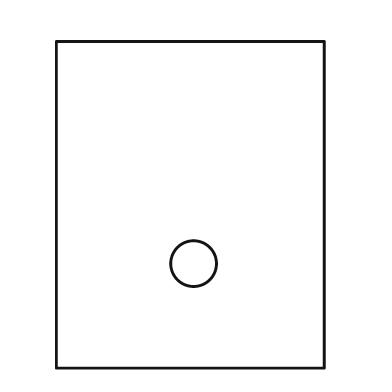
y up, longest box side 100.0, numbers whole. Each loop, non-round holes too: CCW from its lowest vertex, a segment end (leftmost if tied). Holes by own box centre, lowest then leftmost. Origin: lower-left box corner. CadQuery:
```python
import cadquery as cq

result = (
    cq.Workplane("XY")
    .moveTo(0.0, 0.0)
    .lineTo(82.0, 0.0)
    .lineTo(82.0, 100.0)
    .lineTo(0.0, 100.0)
    .close()
    .moveTo(42.0, 32.0)
    .circle(7.0)
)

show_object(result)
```